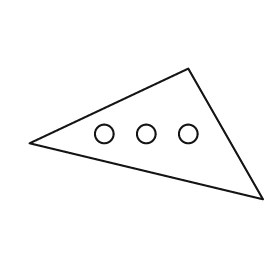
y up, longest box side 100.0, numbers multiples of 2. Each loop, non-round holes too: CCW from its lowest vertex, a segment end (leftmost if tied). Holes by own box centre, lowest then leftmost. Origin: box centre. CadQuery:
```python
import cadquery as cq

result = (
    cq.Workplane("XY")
    .moveTo(50.0, -28.0)
    .lineTo(18.0, 28.0)
    .lineTo(-50.0, -4.0)
    .close()
    .moveTo(-18.0, 0.0)
    .circle(4.0)
    .moveTo(0.0, 0.0)
    .circle(4.0)
    .moveTo(18.0, 0.0)
    .circle(4.0)
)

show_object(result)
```